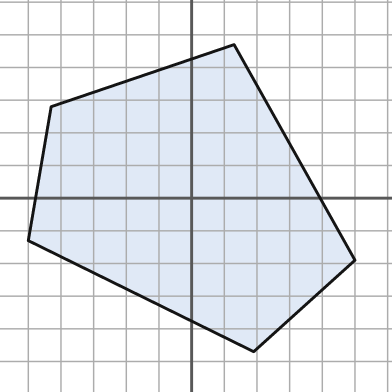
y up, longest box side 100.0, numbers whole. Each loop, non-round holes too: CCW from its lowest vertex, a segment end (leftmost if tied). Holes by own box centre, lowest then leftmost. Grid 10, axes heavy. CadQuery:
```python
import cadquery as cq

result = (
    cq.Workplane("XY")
    .moveTo(19.0, -47.0)
    .lineTo(50.0, -19.0)
    .lineTo(13.0, 47.0)
    .lineTo(-43.0, 28.0)
    .lineTo(-50.0, -13.0)
    .close()
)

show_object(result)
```